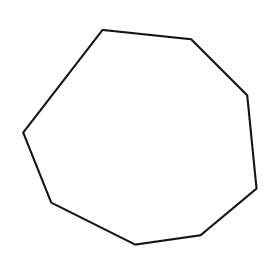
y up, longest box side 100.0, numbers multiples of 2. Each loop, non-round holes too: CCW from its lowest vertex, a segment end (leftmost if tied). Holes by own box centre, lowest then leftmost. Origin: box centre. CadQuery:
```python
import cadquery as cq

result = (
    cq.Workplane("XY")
    .moveTo(-2.0, -46.0)
    .lineTo(26.0, -42.0)
    .lineTo(50.0, -22.0)
    .lineTo(46.0, 18.0)
    .lineTo(22.0, 42.0)
    .lineTo(-16.0, 46.0)
    .lineTo(-50.0, 2.0)
    .lineTo(-38.0, -28.0)
    .close()
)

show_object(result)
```